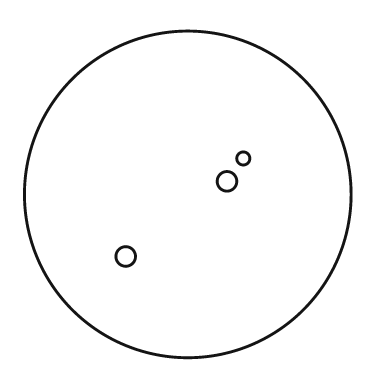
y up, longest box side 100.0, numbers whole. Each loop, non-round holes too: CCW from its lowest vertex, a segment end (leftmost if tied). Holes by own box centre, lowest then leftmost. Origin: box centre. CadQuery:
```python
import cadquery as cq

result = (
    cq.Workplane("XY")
    .moveTo(0.0, 0.0)
    .circle(50.0)
    .moveTo(-19.0, -19.0)
    .circle(3.0)
    .moveTo(12.0, 4.0)
    .circle(3.0)
    .moveTo(17.0, 11.0)
    .circle(2.0)
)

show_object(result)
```